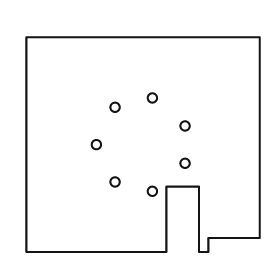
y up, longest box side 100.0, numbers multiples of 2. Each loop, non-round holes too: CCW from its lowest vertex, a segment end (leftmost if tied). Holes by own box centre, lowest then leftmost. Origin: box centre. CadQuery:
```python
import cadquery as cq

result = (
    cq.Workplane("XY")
    .moveTo(-50.0, -46.0)
    .lineTo(10.0, -46.0)
    .lineTo(10.0, -18.0)
    .lineTo(24.0, -18.0)
    .lineTo(24.0, -46.0)
    .lineTo(28.0, -46.0)
    .lineTo(28.0, -40.0)
    .lineTo(50.0, -40.0)
    .lineTo(50.0, 46.0)
    .lineTo(-50.0, 46.0)
    .close()
    .moveTo(4.0, -20.0)
    .circle(2.0)
    .moveTo(-12.0, -16.0)
    .circle(2.0)
    .moveTo(18.0, -8.0)
    .circle(2.0)
    .moveTo(-20.0, 0.0)
    .circle(2.0)
    .moveTo(18.0, 8.0)
    .circle(2.0)
    .moveTo(-12.0, 16.0)
    .circle(2.0)
    .moveTo(4.0, 20.0)
    .circle(2.0)
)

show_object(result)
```